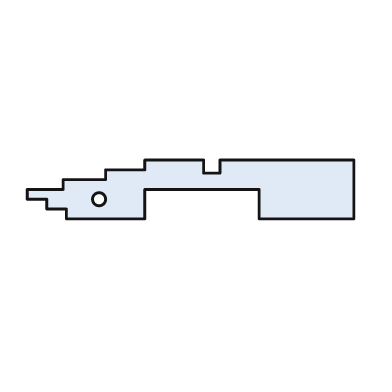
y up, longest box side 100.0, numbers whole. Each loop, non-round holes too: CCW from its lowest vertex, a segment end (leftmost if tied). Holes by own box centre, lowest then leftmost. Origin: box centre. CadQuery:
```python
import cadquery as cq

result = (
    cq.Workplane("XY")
    .moveTo(-38.0, -9.0)
    .lineTo(-14.0, -9.0)
    .lineTo(-14.0, 0.0)
    .lineTo(21.0, 0.0)
    .lineTo(21.0, -9.0)
    .lineTo(50.0, -9.0)
    .lineTo(50.0, 9.0)
    .lineTo(9.0, 9.0)
    .lineTo(9.0, 5.0)
    .lineTo(4.0, 5.0)
    .lineTo(4.0, 9.0)
    .lineTo(-14.0, 9.0)
    .lineTo(-14.0, 6.0)
    .lineTo(-26.0, 6.0)
    .lineTo(-26.0, 3.0)
    .lineTo(-39.0, 3.0)
    .lineTo(-39.0, 0.0)
    .lineTo(-50.0, 0.0)
    .lineTo(-50.0, -3.0)
    .lineTo(-44.0, -3.0)
    .lineTo(-44.0, -6.0)
    .lineTo(-38.0, -6.0)
    .close()
    .moveTo(-28.0, -3.0)
    .circle(2.0)
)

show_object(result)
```